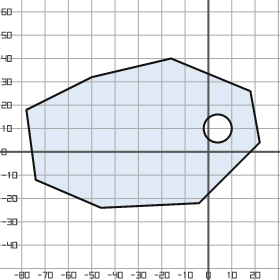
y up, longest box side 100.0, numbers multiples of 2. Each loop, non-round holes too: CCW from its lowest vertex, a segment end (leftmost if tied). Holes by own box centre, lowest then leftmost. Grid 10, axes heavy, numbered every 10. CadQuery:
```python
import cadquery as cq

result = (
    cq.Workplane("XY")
    .moveTo(-46.0, -24.0)
    .lineTo(-4.0, -22.0)
    .lineTo(22.0, 4.0)
    .lineTo(18.0, 26.0)
    .lineTo(-16.0, 40.0)
    .lineTo(-50.0, 32.0)
    .lineTo(-78.0, 18.0)
    .lineTo(-74.0, -12.0)
    .close()
    .moveTo(4.0, 10.0)
    .circle(6.0)
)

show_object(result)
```